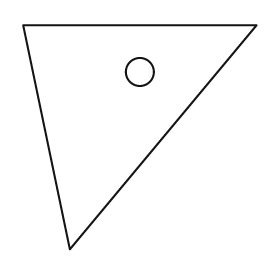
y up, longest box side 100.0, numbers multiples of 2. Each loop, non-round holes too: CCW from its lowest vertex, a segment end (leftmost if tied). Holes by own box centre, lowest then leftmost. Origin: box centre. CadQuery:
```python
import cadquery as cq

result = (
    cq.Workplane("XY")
    .moveTo(-30.0, -48.0)
    .lineTo(50.0, 48.0)
    .lineTo(-50.0, 48.0)
    .close()
    .moveTo(0.0, 28.0)
    .circle(6.0)
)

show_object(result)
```